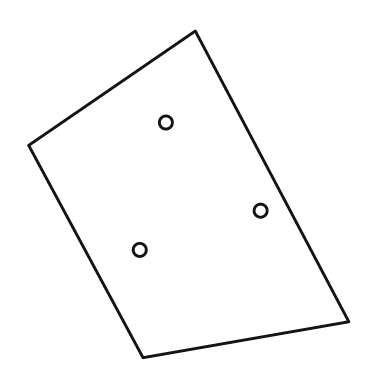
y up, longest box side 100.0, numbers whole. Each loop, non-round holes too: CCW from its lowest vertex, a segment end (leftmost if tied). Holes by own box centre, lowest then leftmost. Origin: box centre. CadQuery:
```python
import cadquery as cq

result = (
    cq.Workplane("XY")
    .moveTo(-14.0, -50.0)
    .lineTo(49.0, -39.0)
    .lineTo(2.0, 50.0)
    .lineTo(-49.0, 15.0)
    .close()
    .moveTo(-15.0, -17.0)
    .circle(2.0)
    .moveTo(22.0, -5.0)
    .circle(2.0)
    .moveTo(-7.0, 22.0)
    .circle(2.0)
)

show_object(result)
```